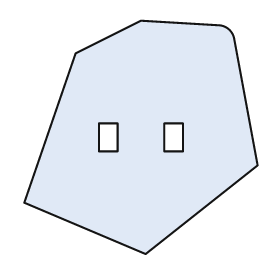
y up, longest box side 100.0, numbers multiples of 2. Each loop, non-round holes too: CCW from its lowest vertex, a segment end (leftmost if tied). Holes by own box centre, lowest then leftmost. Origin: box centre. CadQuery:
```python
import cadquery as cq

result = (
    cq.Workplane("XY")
    .moveTo(2.0, -50.0)
    .lineTo(50.0, -12.0)
    .lineTo(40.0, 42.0)
    .threePointArc((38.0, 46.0), (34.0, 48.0))
    .lineTo(0.0, 50.0)
    .lineTo(-28.0, 36.0)
    .lineTo(-50.0, -28.0)
    .close()
    .moveTo(-18.0, -6.0)
    .lineTo(-10.0, -6.0)
    .lineTo(-10.0, 6.0)
    .lineTo(-18.0, 6.0)
    .close()
    .moveTo(10.0, -6.0)
    .lineTo(18.0, -6.0)
    .lineTo(18.0, 6.0)
    .lineTo(10.0, 6.0)
    .close()
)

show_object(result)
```